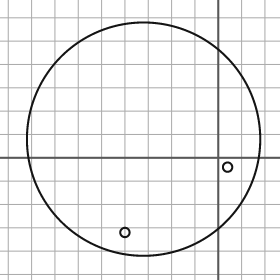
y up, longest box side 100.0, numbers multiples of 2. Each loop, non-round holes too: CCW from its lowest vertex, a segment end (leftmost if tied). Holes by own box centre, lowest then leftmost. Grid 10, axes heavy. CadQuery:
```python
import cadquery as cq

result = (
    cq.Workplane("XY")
    .moveTo(-32.0, 8.0)
    .circle(50.0)
    .moveTo(-40.0, -32.0)
    .circle(2.0)
    .moveTo(4.0, -4.0)
    .circle(2.0)
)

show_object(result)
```